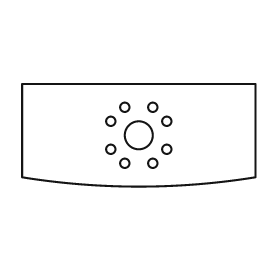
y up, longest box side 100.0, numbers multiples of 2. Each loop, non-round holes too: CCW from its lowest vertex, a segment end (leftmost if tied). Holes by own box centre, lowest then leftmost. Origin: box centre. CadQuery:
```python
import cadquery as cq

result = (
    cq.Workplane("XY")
    .moveTo(-50.0, -18.0)
    .threePointArc((0.0, -22.0), (50.0, -18.0))
    .lineTo(50.0, 22.0)
    .lineTo(-50.0, 22.0)
    .close()
    .moveTo(-6.0, -12.0)
    .circle(2.0)
    .moveTo(6.0, -12.0)
    .circle(2.0)
    .moveTo(-12.0, -6.0)
    .circle(2.0)
    .moveTo(12.0, -6.0)
    .circle(2.0)
    .moveTo(0.0, 0.0)
    .circle(6.0)
    .moveTo(-12.0, 6.0)
    .circle(2.0)
    .moveTo(12.0, 6.0)
    .circle(2.0)
    .moveTo(-6.0, 12.0)
    .circle(2.0)
    .moveTo(6.0, 12.0)
    .circle(2.0)
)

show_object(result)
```